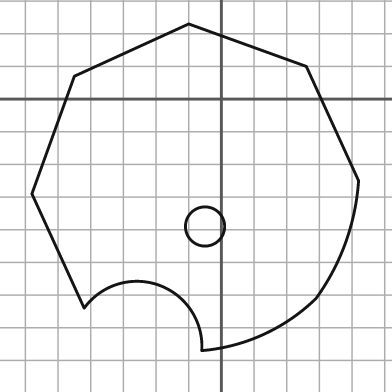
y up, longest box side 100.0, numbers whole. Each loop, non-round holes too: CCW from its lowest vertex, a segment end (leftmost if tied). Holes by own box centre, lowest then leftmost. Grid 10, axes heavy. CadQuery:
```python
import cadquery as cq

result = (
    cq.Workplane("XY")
    .moveTo(-6.0, -77.0)
    .threePointArc((13.0, -72.0), (29.0, -61.0))
    .threePointArc((38.0, -44.0), (42.0, -25.0))
    .lineTo(26.0, 10.0)
    .lineTo(-10.0, 23.0)
    .lineTo(-45.0, 7.0)
    .lineTo(-58.0, -29.0)
    .lineTo(-42.0, -64.0)
    .threePointArc((-19.0, -57.0), (-6.0, -77.0))
    .close()
    .moveTo(-5.0, -39.0)
    .circle(6.0)
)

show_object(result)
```